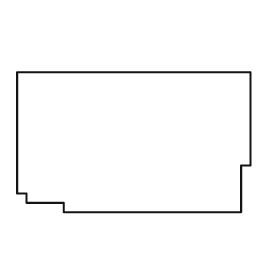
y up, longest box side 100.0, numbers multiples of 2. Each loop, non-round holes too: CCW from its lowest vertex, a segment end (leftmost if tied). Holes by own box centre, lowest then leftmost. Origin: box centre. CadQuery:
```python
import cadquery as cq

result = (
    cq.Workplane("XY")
    .moveTo(-30.0, -30.0)
    .lineTo(46.0, -30.0)
    .lineTo(46.0, -10.0)
    .lineTo(50.0, -10.0)
    .lineTo(50.0, 30.0)
    .lineTo(-50.0, 30.0)
    .lineTo(-50.0, -22.0)
    .lineTo(-46.0, -22.0)
    .lineTo(-46.0, -26.0)
    .lineTo(-30.0, -26.0)
    .close()
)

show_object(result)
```